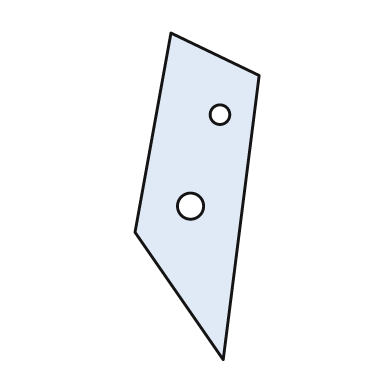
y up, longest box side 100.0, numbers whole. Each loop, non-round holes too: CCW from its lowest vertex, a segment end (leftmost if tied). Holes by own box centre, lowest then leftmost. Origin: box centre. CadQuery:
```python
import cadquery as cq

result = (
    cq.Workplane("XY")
    .moveTo(8.0, -50.0)
    .lineTo(19.0, 37.0)
    .lineTo(-8.0, 50.0)
    .lineTo(-19.0, -11.0)
    .close()
    .moveTo(-2.0, -3.0)
    .circle(4.0)
    .moveTo(7.0, 25.0)
    .circle(3.0)
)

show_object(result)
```